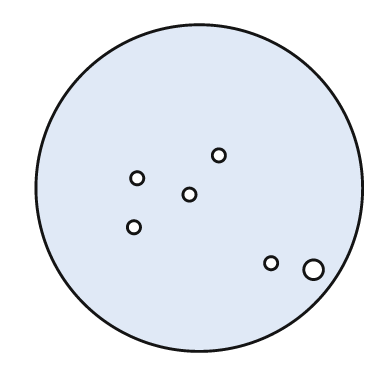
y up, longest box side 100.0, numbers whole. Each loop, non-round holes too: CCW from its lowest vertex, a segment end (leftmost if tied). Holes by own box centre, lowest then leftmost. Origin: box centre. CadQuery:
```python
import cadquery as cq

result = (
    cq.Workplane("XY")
    .moveTo(0.0, 0.0)
    .circle(50.0)
    .moveTo(35.0, -25.0)
    .circle(3.0)
    .moveTo(22.0, -23.0)
    .circle(2.0)
    .moveTo(-20.0, -12.0)
    .circle(2.0)
    .moveTo(-3.0, -2.0)
    .circle(2.0)
    .moveTo(-19.0, 3.0)
    .circle(2.0)
    .moveTo(6.0, 10.0)
    .circle(2.0)
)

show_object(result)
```